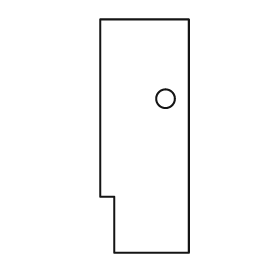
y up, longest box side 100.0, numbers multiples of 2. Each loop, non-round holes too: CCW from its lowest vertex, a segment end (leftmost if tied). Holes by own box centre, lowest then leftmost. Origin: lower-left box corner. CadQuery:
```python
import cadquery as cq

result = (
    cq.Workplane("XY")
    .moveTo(6.0, 0.0)
    .lineTo(38.0, 0.0)
    .lineTo(38.0, 100.0)
    .lineTo(0.0, 100.0)
    .lineTo(0.0, 24.0)
    .lineTo(6.0, 24.0)
    .close()
    .moveTo(28.0, 66.0)
    .circle(4.0)
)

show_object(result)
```